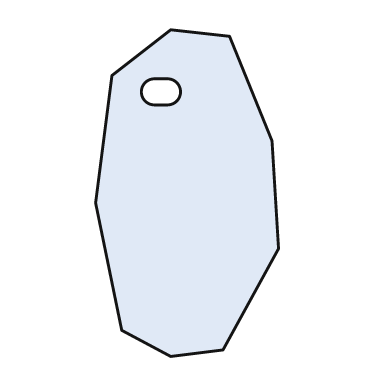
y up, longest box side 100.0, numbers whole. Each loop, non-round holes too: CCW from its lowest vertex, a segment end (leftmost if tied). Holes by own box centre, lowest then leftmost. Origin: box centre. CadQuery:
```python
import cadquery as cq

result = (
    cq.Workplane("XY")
    .moveTo(-5.0, -50.0)
    .lineTo(11.0, -48.0)
    .lineTo(28.0, -17.0)
    .lineTo(26.0, 16.0)
    .lineTo(13.0, 48.0)
    .lineTo(-5.0, 50.0)
    .lineTo(-23.0, 36.0)
    .lineTo(-28.0, -3.0)
    .lineTo(-20.0, -42.0)
    .close()
    .moveTo(-10.0, 27.0)
    .lineTo(-6.0, 27.0)
    .threePointArc((-2.0, 31.0), (-6.0, 35.0))
    .lineTo(-10.0, 35.0)
    .threePointArc((-14.0, 31.0), (-10.0, 27.0))
    .close()
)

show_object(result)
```